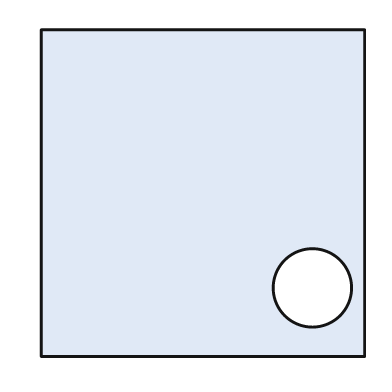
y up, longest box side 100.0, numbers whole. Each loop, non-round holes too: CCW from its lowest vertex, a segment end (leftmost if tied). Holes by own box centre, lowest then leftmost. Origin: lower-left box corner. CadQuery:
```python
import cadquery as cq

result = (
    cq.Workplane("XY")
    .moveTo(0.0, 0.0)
    .lineTo(99.0, 0.0)
    .lineTo(99.0, 100.0)
    .lineTo(0.0, 100.0)
    .close()
    .moveTo(83.0, 21.0)
    .circle(12.0)
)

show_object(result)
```